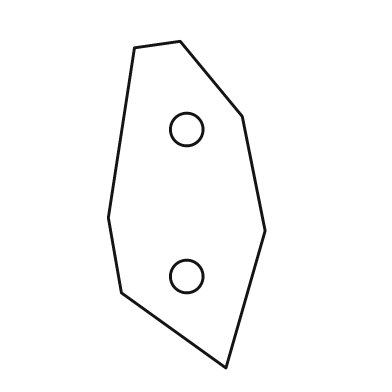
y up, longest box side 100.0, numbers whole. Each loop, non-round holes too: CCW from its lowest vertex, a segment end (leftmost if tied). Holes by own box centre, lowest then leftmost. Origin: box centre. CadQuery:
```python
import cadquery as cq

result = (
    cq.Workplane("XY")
    .moveTo(12.0, -50.0)
    .lineTo(24.0, -8.0)
    .lineTo(17.0, 27.0)
    .lineTo(-2.0, 50.0)
    .lineTo(-16.0, 48.0)
    .lineTo(-24.0, -4.0)
    .lineTo(-20.0, -27.0)
    .close()
    .moveTo(0.0, -22.0)
    .circle(5.0)
    .moveTo(0.0, 23.0)
    .circle(5.0)
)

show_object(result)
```